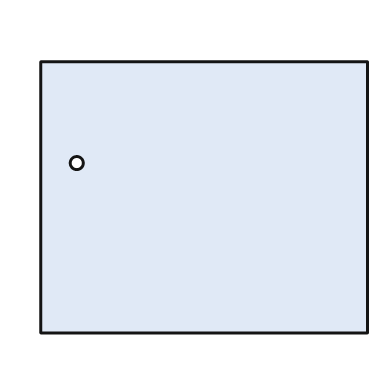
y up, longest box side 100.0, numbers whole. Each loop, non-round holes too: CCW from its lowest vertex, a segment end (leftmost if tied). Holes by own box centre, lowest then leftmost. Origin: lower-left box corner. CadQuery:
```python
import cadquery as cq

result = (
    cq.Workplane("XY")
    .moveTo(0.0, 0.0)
    .lineTo(100.0, 0.0)
    .lineTo(100.0, 83.0)
    .lineTo(0.0, 83.0)
    .close()
    .moveTo(11.0, 52.0)
    .circle(2.0)
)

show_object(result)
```